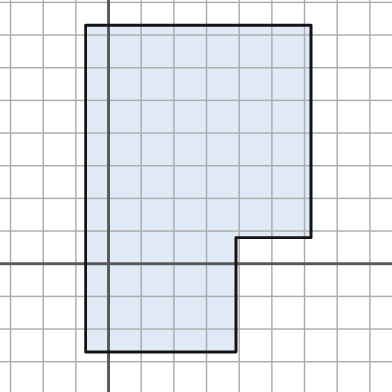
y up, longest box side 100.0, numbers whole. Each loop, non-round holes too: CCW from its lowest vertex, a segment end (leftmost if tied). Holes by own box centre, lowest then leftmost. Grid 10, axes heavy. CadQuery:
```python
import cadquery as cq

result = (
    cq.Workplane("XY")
    .moveTo(-7.0, -27.0)
    .lineTo(39.0, -27.0)
    .lineTo(39.0, 8.0)
    .lineTo(62.0, 8.0)
    .lineTo(62.0, 73.0)
    .lineTo(-7.0, 73.0)
    .close()
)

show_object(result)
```